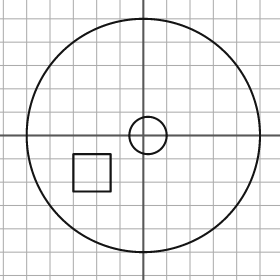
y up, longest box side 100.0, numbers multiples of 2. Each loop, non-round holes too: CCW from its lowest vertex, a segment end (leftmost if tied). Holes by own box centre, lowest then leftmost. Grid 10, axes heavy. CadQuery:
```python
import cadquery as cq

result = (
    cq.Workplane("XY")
    .moveTo(0.0, 0.0)
    .circle(50.0)
    .moveTo(-30.0, -24.0)
    .lineTo(-14.0, -24.0)
    .lineTo(-14.0, -8.0)
    .lineTo(-30.0, -8.0)
    .close()
    .moveTo(2.0, 0.0)
    .circle(8.0)
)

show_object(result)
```